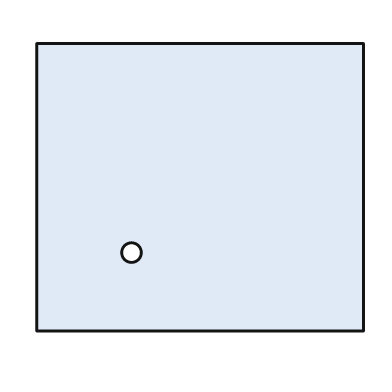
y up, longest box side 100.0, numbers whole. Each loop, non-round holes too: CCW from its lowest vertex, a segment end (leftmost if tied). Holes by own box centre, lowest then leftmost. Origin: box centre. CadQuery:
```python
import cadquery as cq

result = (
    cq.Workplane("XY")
    .moveTo(-50.0, -44.0)
    .lineTo(50.0, -44.0)
    .lineTo(50.0, 44.0)
    .lineTo(-50.0, 44.0)
    .close()
    .moveTo(-21.0, -20.0)
    .circle(3.0)
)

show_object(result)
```